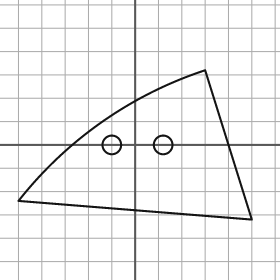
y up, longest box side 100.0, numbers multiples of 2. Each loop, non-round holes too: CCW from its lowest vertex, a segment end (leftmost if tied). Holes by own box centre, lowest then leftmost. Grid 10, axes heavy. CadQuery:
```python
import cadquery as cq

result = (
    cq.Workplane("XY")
    .moveTo(50.0, -32.0)
    .lineTo(30.0, 32.0)
    .threePointArc((-14.0, 10.0), (-50.0, -24.0))
    .close()
    .moveTo(-10.0, 0.0)
    .circle(4.0)
    .moveTo(12.0, 0.0)
    .circle(4.0)
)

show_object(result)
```